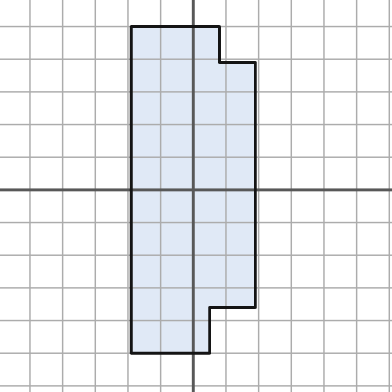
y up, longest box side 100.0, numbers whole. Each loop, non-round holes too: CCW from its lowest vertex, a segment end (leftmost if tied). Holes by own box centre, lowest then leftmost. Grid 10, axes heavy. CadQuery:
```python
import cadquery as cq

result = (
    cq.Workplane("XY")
    .moveTo(-19.0, -50.0)
    .lineTo(5.0, -50.0)
    .lineTo(5.0, -36.0)
    .lineTo(19.0, -36.0)
    .lineTo(19.0, 39.0)
    .lineTo(8.0, 39.0)
    .lineTo(8.0, 50.0)
    .lineTo(-19.0, 50.0)
    .close()
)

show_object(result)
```